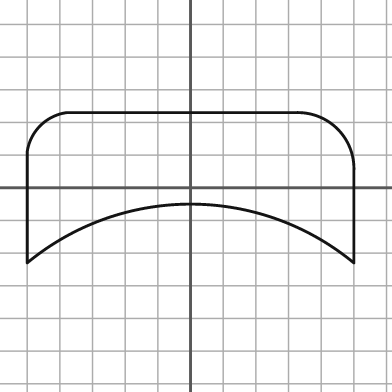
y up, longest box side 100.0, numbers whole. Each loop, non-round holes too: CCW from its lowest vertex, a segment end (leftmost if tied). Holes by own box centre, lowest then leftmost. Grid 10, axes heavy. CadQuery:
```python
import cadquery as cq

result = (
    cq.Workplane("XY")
    .moveTo(-50.0, -23.0)
    .threePointArc((0.0, -5.0), (50.0, -23.0))
    .lineTo(50.0, 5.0)
    .threePointArc((45.0, 18.0), (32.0, 23.0))
    .lineTo(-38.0, 23.0)
    .threePointArc((-46.0, 19.0), (-50.0, 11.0))
    .close()
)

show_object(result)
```